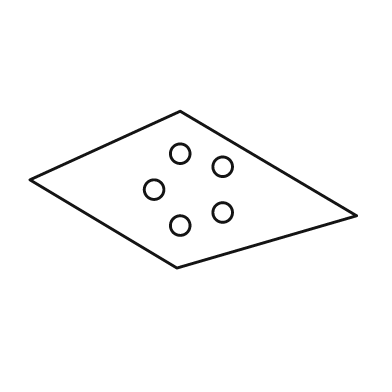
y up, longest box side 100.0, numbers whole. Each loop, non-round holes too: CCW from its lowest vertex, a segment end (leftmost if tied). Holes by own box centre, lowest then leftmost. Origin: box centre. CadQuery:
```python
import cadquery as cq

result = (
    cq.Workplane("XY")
    .moveTo(-5.0, -24.0)
    .lineTo(50.0, -8.0)
    .lineTo(-4.0, 24.0)
    .lineTo(-50.0, 3.0)
    .close()
    .moveTo(-4.0, -11.0)
    .circle(3.0)
    .moveTo(9.0, -7.0)
    .circle(3.0)
    .moveTo(-12.0, 0.0)
    .circle(3.0)
    .moveTo(9.0, 7.0)
    .circle(3.0)
    .moveTo(-4.0, 11.0)
    .circle(3.0)
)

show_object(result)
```